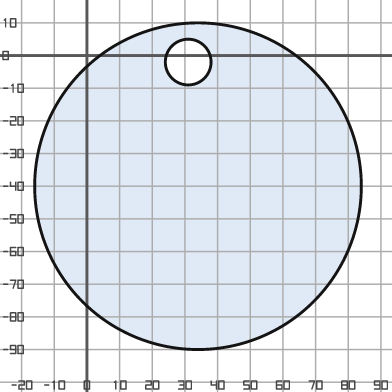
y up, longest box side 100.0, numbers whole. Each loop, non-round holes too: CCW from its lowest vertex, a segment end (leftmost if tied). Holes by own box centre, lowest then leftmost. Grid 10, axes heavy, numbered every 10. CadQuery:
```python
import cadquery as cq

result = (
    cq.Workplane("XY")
    .moveTo(34.0, -40.0)
    .circle(50.0)
    .moveTo(31.0, -2.0)
    .circle(7.0)
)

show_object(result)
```